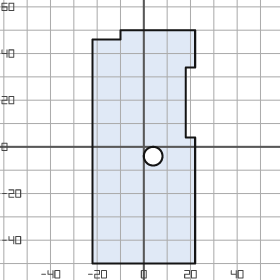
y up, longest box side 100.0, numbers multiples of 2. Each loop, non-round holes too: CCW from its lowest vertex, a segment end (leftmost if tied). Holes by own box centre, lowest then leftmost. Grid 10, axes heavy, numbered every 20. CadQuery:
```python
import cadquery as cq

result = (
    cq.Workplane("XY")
    .moveTo(-22.0, -50.0)
    .lineTo(22.0, -50.0)
    .lineTo(22.0, 4.0)
    .lineTo(18.0, 4.0)
    .lineTo(18.0, 34.0)
    .lineTo(22.0, 34.0)
    .lineTo(22.0, 50.0)
    .lineTo(-10.0, 50.0)
    .lineTo(-10.0, 46.0)
    .lineTo(-22.0, 46.0)
    .close()
    .moveTo(4.0, -4.0)
    .circle(4.0)
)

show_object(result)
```